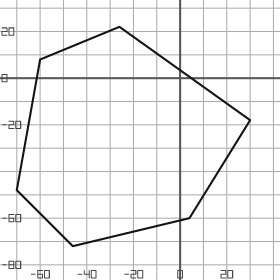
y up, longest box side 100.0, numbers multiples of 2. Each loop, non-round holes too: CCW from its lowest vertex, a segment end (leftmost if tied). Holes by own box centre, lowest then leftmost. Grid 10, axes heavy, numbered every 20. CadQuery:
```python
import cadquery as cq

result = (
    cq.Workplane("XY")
    .moveTo(-46.0, -72.0)
    .lineTo(4.0, -60.0)
    .lineTo(30.0, -18.0)
    .lineTo(-26.0, 22.0)
    .lineTo(-60.0, 8.0)
    .lineTo(-70.0, -48.0)
    .close()
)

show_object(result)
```